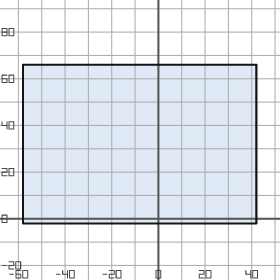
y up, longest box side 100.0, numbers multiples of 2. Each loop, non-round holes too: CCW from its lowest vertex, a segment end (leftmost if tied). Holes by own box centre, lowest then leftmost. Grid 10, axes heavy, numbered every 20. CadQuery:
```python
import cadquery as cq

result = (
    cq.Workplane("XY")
    .moveTo(-58.0, -2.0)
    .lineTo(42.0, -2.0)
    .lineTo(42.0, 66.0)
    .lineTo(-58.0, 66.0)
    .close()
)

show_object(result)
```